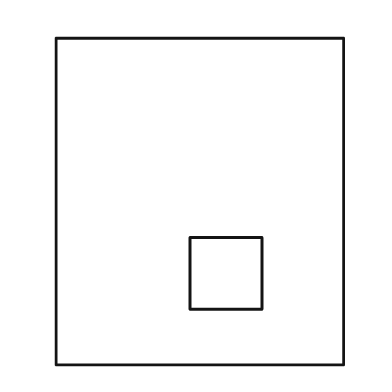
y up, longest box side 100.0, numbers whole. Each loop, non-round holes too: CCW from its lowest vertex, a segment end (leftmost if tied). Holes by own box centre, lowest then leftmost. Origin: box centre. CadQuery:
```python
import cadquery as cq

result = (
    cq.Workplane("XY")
    .moveTo(-44.0, -50.0)
    .lineTo(44.0, -50.0)
    .lineTo(44.0, 50.0)
    .lineTo(-44.0, 50.0)
    .close()
    .moveTo(-3.0, -33.0)
    .lineTo(19.0, -33.0)
    .lineTo(19.0, -11.0)
    .lineTo(-3.0, -11.0)
    .close()
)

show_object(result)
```